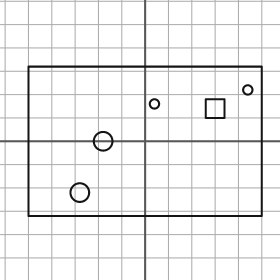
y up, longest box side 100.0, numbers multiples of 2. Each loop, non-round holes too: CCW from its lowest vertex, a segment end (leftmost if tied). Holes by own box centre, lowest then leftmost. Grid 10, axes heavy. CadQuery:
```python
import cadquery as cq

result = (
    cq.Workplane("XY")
    .moveTo(-50.0, -32.0)
    .lineTo(50.0, -32.0)
    .lineTo(50.0, 32.0)
    .lineTo(-50.0, 32.0)
    .close()
    .moveTo(-28.0, -22.0)
    .circle(4.0)
    .moveTo(-18.0, 0.0)
    .circle(4.0)
    .moveTo(26.0, 10.0)
    .lineTo(34.0, 10.0)
    .lineTo(34.0, 18.0)
    .lineTo(26.0, 18.0)
    .close()
    .moveTo(4.0, 16.0)
    .circle(2.0)
    .moveTo(44.0, 22.0)
    .circle(2.0)
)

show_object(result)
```